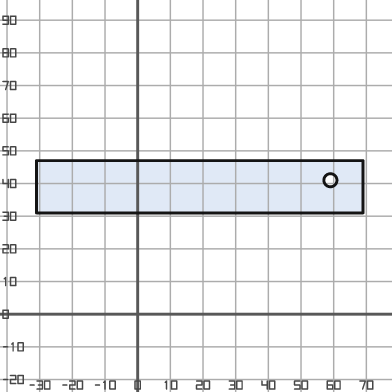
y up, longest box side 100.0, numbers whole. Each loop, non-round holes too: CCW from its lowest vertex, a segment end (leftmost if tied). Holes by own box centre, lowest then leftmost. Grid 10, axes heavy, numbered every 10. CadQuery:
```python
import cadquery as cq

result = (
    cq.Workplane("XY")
    .moveTo(-31.0, 31.0)
    .lineTo(69.0, 31.0)
    .lineTo(69.0, 47.0)
    .lineTo(-31.0, 47.0)
    .close()
    .moveTo(59.0, 41.0)
    .circle(2.0)
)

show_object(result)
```